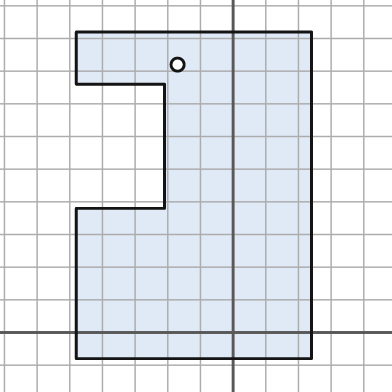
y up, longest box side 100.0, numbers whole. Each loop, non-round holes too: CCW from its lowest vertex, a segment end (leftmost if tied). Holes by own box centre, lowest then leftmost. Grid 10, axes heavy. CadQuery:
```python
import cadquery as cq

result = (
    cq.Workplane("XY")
    .moveTo(-48.0, -8.0)
    .lineTo(24.0, -8.0)
    .lineTo(24.0, 92.0)
    .lineTo(-48.0, 92.0)
    .lineTo(-48.0, 76.0)
    .lineTo(-21.0, 76.0)
    .lineTo(-21.0, 38.0)
    .lineTo(-48.0, 38.0)
    .close()
    .moveTo(-17.0, 82.0)
    .circle(2.0)
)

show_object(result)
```